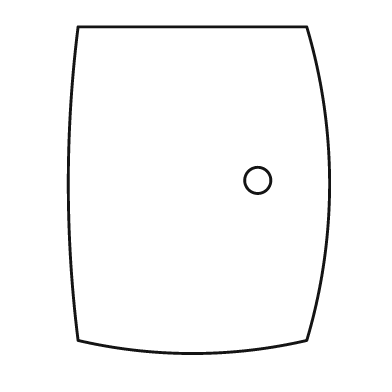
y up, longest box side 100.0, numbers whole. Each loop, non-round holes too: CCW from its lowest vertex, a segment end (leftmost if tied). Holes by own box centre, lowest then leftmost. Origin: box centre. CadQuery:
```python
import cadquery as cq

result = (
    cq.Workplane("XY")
    .moveTo(-37.0, -46.0)
    .threePointArc((-2.0, -50.0), (33.0, -46.0))
    .threePointArc((40.0, 2.0), (33.0, 50.0))
    .lineTo(-37.0, 50.0)
    .threePointArc((-40.0, 2.0), (-37.0, -46.0))
    .close()
    .moveTo(18.0, 3.0)
    .circle(4.0)
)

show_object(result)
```